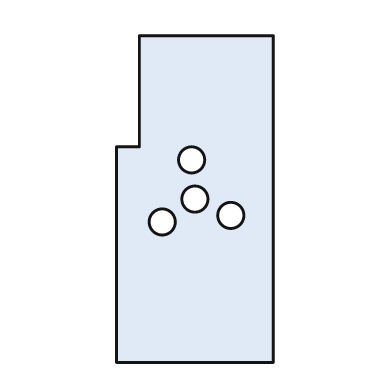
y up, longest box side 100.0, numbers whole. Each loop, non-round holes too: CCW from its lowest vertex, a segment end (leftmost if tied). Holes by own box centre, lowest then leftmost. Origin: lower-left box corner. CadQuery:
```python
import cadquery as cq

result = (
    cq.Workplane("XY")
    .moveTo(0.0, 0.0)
    .lineTo(48.0, 0.0)
    .lineTo(48.0, 100.0)
    .lineTo(7.0, 100.0)
    .lineTo(7.0, 66.0)
    .lineTo(0.0, 66.0)
    .close()
    .moveTo(14.0, 43.0)
    .circle(4.0)
    .moveTo(35.0, 45.0)
    .circle(4.0)
    .moveTo(24.0, 50.0)
    .circle(4.0)
    .moveTo(23.0, 62.0)
    .circle(4.0)
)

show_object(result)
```